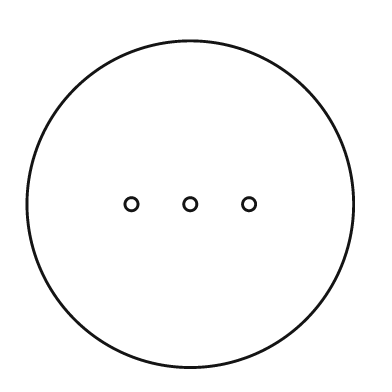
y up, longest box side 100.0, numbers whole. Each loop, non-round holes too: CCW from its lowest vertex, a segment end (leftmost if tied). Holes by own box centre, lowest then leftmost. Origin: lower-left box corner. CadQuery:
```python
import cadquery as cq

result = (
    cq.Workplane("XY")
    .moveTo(50.0, 50.0)
    .circle(50.0)
    .moveTo(32.0, 50.0)
    .circle(2.0)
    .moveTo(50.0, 50.0)
    .circle(2.0)
    .moveTo(68.0, 50.0)
    .circle(2.0)
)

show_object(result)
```